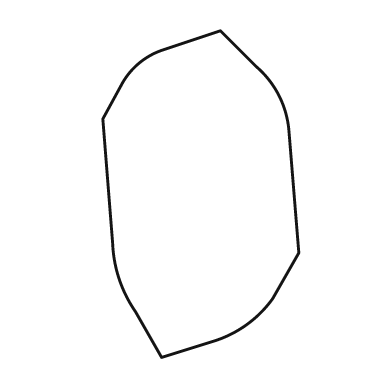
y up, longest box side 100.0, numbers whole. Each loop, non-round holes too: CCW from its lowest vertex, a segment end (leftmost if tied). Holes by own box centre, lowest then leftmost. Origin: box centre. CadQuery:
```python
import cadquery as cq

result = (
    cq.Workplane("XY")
    .moveTo(-12.0, -50.0)
    .lineTo(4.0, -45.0)
    .threePointArc((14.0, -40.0), (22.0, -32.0))
    .lineTo(30.0, -18.0)
    .lineTo(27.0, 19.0)
    .threePointArc((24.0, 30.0), (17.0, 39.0))
    .lineTo(6.0, 50.0)
    .lineTo(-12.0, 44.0)
    .threePointArc((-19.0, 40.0), (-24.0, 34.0))
    .lineTo(-30.0, 23.0)
    .lineTo(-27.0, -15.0)
    .threePointArc((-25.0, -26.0), (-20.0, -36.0))
    .close()
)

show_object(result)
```